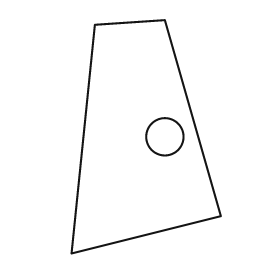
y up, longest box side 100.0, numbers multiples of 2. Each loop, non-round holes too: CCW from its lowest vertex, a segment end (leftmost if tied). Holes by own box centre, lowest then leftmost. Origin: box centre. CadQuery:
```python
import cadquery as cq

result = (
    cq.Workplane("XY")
    .moveTo(-32.0, -50.0)
    .lineTo(32.0, -34.0)
    .lineTo(8.0, 50.0)
    .lineTo(-22.0, 48.0)
    .close()
    .moveTo(8.0, 0.0)
    .circle(8.0)
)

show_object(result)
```